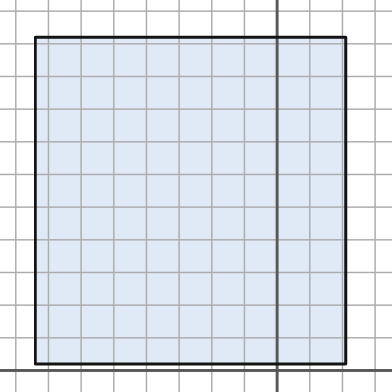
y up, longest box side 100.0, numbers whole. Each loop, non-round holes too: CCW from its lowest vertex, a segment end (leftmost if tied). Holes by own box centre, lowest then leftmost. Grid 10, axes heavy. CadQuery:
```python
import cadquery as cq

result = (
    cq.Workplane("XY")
    .moveTo(-74.0, 2.0)
    .lineTo(21.0, 2.0)
    .lineTo(21.0, 102.0)
    .lineTo(-74.0, 102.0)
    .close()
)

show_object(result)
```